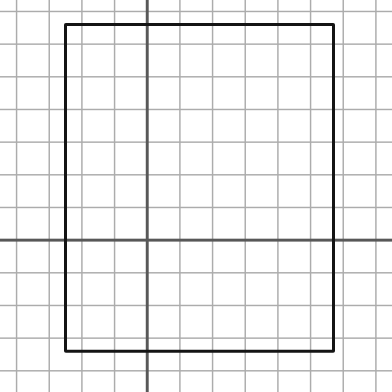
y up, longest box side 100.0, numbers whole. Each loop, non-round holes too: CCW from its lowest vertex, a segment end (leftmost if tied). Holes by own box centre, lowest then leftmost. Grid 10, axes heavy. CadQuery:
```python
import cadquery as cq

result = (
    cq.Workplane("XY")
    .moveTo(-25.0, -34.0)
    .lineTo(57.0, -34.0)
    .lineTo(57.0, 66.0)
    .lineTo(-25.0, 66.0)
    .close()
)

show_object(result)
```